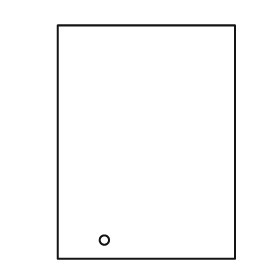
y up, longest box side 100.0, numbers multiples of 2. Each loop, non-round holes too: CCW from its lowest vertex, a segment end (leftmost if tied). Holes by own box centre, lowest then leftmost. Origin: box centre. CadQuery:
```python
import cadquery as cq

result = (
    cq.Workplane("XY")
    .moveTo(-38.0, -50.0)
    .lineTo(38.0, -50.0)
    .lineTo(38.0, 50.0)
    .lineTo(-38.0, 50.0)
    .close()
    .moveTo(-18.0, -42.0)
    .circle(2.0)
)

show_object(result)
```